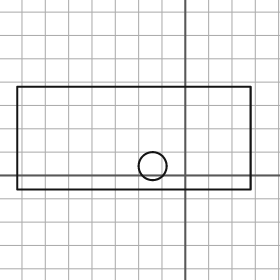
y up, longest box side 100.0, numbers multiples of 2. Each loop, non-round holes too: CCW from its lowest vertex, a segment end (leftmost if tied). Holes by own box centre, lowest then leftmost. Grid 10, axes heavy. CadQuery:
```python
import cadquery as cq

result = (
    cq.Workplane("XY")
    .moveTo(-72.0, -6.0)
    .lineTo(28.0, -6.0)
    .lineTo(28.0, 38.0)
    .lineTo(-72.0, 38.0)
    .close()
    .moveTo(-14.0, 4.0)
    .circle(6.0)
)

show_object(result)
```